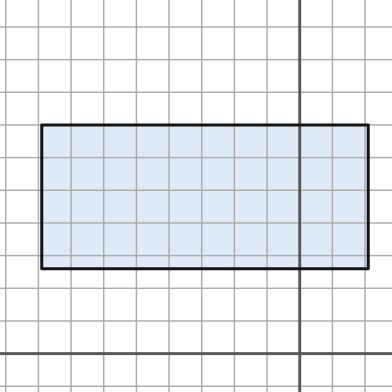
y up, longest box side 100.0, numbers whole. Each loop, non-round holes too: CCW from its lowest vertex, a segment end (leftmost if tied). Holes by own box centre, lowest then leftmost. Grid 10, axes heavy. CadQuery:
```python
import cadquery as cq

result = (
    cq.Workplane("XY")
    .moveTo(-79.0, 26.0)
    .lineTo(21.0, 26.0)
    .lineTo(21.0, 70.0)
    .lineTo(-79.0, 70.0)
    .close()
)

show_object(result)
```